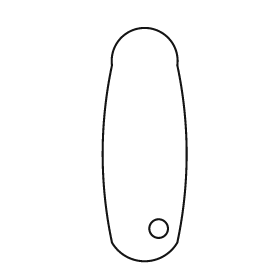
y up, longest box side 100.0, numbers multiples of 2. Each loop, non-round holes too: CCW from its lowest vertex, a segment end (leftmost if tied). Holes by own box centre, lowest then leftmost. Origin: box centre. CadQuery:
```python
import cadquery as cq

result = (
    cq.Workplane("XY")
    .moveTo(-14.0, -42.0)
    .threePointArc((0.0, -50.0), (14.0, -42.0))
    .threePointArc((18.0, -4.0), (14.0, 34.0))
    .threePointArc((0.0, 50.0), (-14.0, 34.0))
    .threePointArc((-18.0, -4.0), (-14.0, -42.0))
    .close()
    .moveTo(6.0, -36.0)
    .circle(4.0)
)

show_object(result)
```